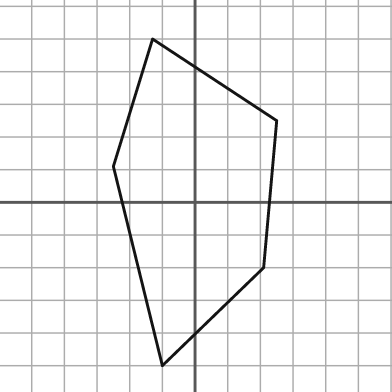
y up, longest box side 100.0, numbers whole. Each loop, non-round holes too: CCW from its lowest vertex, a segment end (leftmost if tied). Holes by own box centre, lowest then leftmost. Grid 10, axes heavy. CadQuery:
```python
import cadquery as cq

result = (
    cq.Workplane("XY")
    .moveTo(-10.0, -50.0)
    .lineTo(21.0, -20.0)
    .lineTo(25.0, 25.0)
    .lineTo(-13.0, 50.0)
    .lineTo(-25.0, 11.0)
    .close()
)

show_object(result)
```